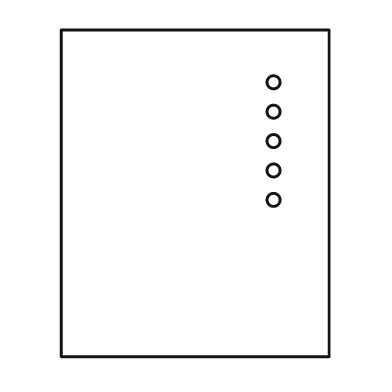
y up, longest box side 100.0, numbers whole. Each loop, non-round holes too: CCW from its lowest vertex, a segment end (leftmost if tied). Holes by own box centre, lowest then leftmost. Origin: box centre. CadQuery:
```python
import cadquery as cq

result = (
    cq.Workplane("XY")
    .moveTo(-41.0, -50.0)
    .lineTo(41.0, -50.0)
    .lineTo(41.0, 50.0)
    .lineTo(-41.0, 50.0)
    .close()
    .moveTo(24.0, -2.0)
    .circle(2.0)
    .moveTo(24.0, 7.0)
    .circle(2.0)
    .moveTo(24.0, 16.0)
    .circle(2.0)
    .moveTo(24.0, 25.0)
    .circle(2.0)
    .moveTo(24.0, 34.0)
    .circle(2.0)
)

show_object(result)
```